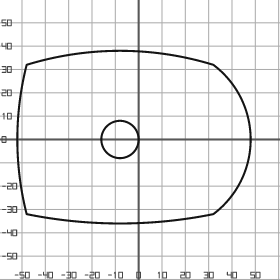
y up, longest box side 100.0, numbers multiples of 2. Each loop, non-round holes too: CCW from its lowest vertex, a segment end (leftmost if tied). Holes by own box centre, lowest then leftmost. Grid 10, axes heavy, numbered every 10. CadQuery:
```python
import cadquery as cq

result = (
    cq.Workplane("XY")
    .moveTo(-48.0, -32.0)
    .threePointArc((-8.0, -36.0), (32.0, -32.0))
    .threePointArc((48.0, 0.0), (32.0, 32.0))
    .threePointArc((-8.0, 38.0), (-48.0, 32.0))
    .threePointArc((-52.0, 0.0), (-48.0, -32.0))
    .close()
    .moveTo(-8.0, 0.0)
    .circle(8.0)
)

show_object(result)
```